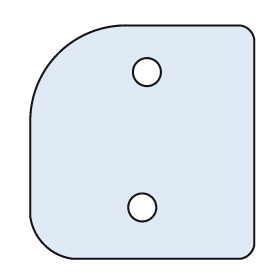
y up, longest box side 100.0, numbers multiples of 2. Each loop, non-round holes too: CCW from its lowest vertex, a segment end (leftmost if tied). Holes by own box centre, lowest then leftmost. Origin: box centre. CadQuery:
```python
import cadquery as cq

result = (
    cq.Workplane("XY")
    .moveTo(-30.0, -50.0)
    .lineTo(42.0, -50.0)
    .threePointArc((46.0, -48.0), (48.0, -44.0))
    .lineTo(48.0, 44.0)
    .threePointArc((46.0, 48.0), (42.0, 50.0))
    .lineTo(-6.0, 50.0)
    .threePointArc((-36.0, 38.0), (-48.0, 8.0))
    .lineTo(-48.0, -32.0)
    .threePointArc((-42.0, -44.0), (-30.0, -50.0))
    .close()
    .moveTo(0.0, -28.0)
    .circle(6.0)
    .moveTo(2.0, 30.0)
    .circle(6.0)
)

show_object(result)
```